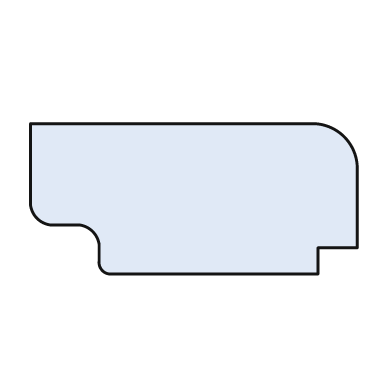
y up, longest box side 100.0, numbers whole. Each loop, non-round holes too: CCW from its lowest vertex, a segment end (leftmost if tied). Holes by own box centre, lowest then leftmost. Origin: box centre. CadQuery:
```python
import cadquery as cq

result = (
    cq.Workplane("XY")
    .moveTo(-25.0, -23.0)
    .lineTo(38.0, -23.0)
    .lineTo(38.0, -15.0)
    .lineTo(50.0, -15.0)
    .lineTo(50.0, 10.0)
    .threePointArc((46.0, 19.0), (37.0, 23.0))
    .lineTo(-50.0, 23.0)
    .lineTo(-50.0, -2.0)
    .threePointArc((-48.0, -6.0), (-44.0, -8.0))
    .lineTo(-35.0, -8.0)
    .threePointArc((-31.0, -10.0), (-29.0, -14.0))
    .lineTo(-29.0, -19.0)
    .threePointArc((-28.0, -22.0), (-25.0, -23.0))
    .close()
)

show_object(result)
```